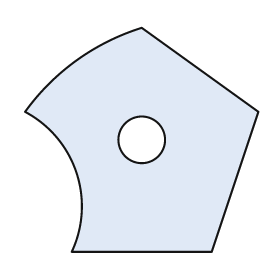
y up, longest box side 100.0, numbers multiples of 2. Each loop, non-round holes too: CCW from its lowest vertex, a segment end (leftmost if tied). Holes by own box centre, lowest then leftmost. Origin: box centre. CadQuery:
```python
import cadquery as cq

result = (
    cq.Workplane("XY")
    .moveTo(-30.0, -48.0)
    .lineTo(30.0, -48.0)
    .lineTo(50.0, 12.0)
    .lineTo(0.0, 48.0)
    .threePointArc((-28.0, 34.0), (-50.0, 12.0))
    .threePointArc((-28.0, -14.0), (-30.0, -48.0))
    .close()
    .moveTo(0.0, 0.0)
    .circle(10.0)
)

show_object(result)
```